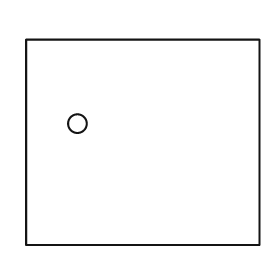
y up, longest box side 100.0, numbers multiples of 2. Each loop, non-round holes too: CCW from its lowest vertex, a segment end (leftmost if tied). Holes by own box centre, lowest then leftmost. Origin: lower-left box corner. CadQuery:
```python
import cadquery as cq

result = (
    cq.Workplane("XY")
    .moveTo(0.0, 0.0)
    .lineTo(100.0, 0.0)
    .lineTo(100.0, 88.0)
    .lineTo(0.0, 88.0)
    .close()
    .moveTo(22.0, 52.0)
    .circle(4.0)
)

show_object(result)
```